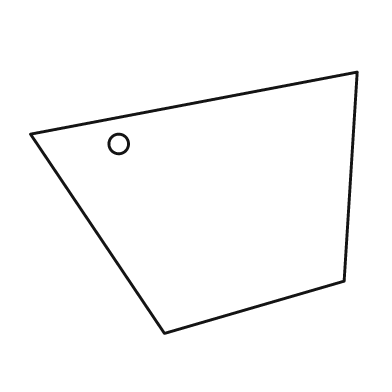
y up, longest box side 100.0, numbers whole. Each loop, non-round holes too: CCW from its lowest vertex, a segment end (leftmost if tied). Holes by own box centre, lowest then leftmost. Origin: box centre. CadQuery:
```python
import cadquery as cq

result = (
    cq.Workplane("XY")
    .moveTo(-9.0, -40.0)
    .lineTo(46.0, -24.0)
    .lineTo(50.0, 40.0)
    .lineTo(-50.0, 21.0)
    .close()
    .moveTo(-23.0, 18.0)
    .circle(3.0)
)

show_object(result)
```